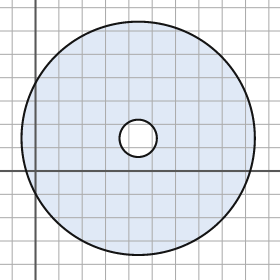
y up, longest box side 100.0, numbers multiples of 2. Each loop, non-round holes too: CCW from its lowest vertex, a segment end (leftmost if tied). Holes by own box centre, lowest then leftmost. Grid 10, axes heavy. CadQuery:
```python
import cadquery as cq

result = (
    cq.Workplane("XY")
    .moveTo(44.0, 14.0)
    .circle(50.0)
    .moveTo(44.0, 14.0)
    .circle(8.0)
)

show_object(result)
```